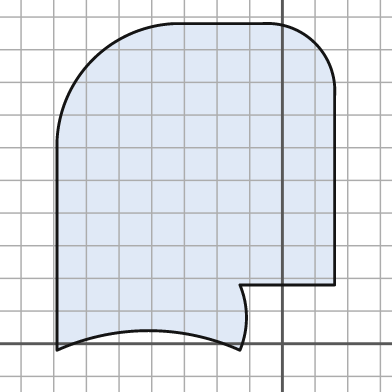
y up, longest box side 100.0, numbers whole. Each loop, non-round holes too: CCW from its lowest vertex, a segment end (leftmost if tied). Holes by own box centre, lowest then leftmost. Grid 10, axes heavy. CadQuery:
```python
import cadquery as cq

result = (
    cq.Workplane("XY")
    .moveTo(-69.0, -2.0)
    .threePointArc((-41.0, 4.0), (-13.0, -2.0))
    .threePointArc((-11.0, 8.0), (-13.0, 18.0))
    .lineTo(16.0, 18.0)
    .lineTo(16.0, 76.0)
    .threePointArc((10.0, 92.0), (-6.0, 98.0))
    .lineTo(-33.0, 98.0)
    .threePointArc((-58.0, 87.0), (-69.0, 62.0))
    .close()
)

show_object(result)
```